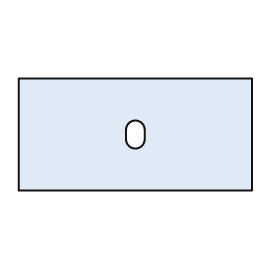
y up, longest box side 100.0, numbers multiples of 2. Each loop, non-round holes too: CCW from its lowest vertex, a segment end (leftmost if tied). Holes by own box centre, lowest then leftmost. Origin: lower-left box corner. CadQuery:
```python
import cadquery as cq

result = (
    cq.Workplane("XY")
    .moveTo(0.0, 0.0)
    .lineTo(100.0, 0.0)
    .lineTo(100.0, 48.0)
    .lineTo(0.0, 48.0)
    .close()
    .moveTo(46.0, 22.0)
    .threePointArc((50.0, 18.0), (54.0, 22.0))
    .lineTo(54.0, 26.0)
    .threePointArc((50.0, 30.0), (46.0, 26.0))
    .close()
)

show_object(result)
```